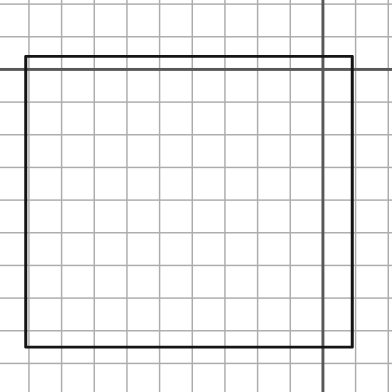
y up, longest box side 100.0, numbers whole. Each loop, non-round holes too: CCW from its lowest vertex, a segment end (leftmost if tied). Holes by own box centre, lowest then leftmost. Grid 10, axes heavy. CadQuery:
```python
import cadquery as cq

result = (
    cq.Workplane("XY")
    .moveTo(-91.0, -85.0)
    .lineTo(9.0, -85.0)
    .lineTo(9.0, 4.0)
    .lineTo(-91.0, 4.0)
    .close()
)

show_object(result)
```